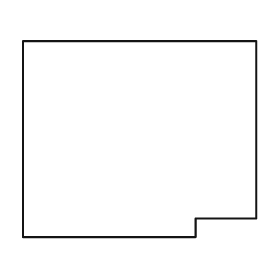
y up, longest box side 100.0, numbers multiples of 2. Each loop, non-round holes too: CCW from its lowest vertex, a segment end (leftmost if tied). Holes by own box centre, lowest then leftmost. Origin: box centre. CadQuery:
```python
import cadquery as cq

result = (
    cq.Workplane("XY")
    .moveTo(-50.0, -42.0)
    .lineTo(24.0, -42.0)
    .lineTo(24.0, -34.0)
    .lineTo(50.0, -34.0)
    .lineTo(50.0, 42.0)
    .lineTo(-50.0, 42.0)
    .close()
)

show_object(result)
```